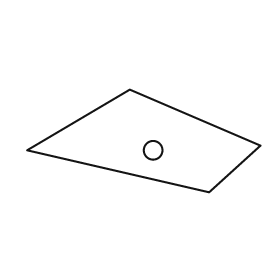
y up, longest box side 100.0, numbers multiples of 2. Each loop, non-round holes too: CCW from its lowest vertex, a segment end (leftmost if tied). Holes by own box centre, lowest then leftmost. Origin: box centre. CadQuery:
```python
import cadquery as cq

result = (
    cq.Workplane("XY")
    .moveTo(28.0, -22.0)
    .lineTo(50.0, -2.0)
    .lineTo(-6.0, 22.0)
    .lineTo(-50.0, -4.0)
    .close()
    .moveTo(4.0, -4.0)
    .circle(4.0)
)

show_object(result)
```